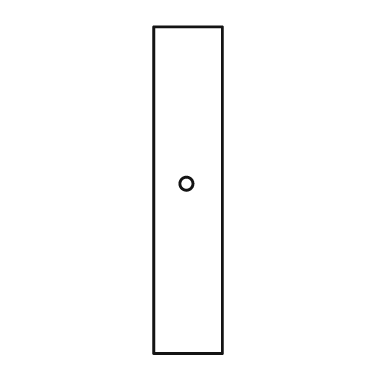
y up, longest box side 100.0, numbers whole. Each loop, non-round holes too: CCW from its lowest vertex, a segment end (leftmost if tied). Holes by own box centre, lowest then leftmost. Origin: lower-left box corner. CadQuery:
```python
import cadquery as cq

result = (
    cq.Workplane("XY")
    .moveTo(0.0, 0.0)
    .lineTo(21.0, 0.0)
    .lineTo(21.0, 100.0)
    .lineTo(0.0, 100.0)
    .close()
    .moveTo(10.0, 52.0)
    .circle(2.0)
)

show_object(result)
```